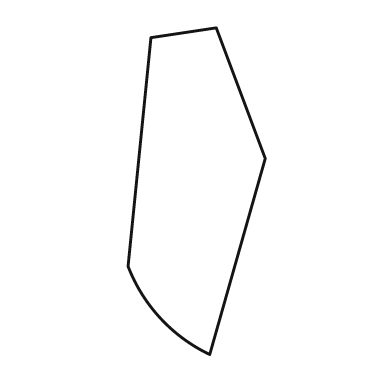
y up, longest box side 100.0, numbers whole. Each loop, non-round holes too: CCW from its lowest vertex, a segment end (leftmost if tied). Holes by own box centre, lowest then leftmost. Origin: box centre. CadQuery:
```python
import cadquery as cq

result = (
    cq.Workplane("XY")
    .moveTo(4.0, -50.0)
    .lineTo(21.0, 10.0)
    .lineTo(6.0, 50.0)
    .lineTo(-14.0, 47.0)
    .lineTo(-21.0, -23.0)
    .threePointArc((-11.0, -39.0), (4.0, -50.0))
    .close()
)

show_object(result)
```